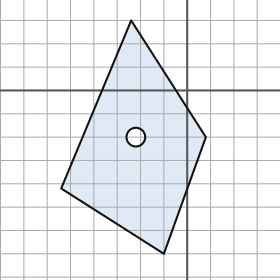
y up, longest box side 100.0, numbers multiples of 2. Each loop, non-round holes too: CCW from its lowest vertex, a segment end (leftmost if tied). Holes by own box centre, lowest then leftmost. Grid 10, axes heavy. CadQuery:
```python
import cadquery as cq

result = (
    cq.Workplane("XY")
    .moveTo(-10.0, -70.0)
    .lineTo(8.0, -20.0)
    .lineTo(-24.0, 30.0)
    .lineTo(-54.0, -42.0)
    .close()
    .moveTo(-22.0, -20.0)
    .circle(4.0)
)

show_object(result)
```